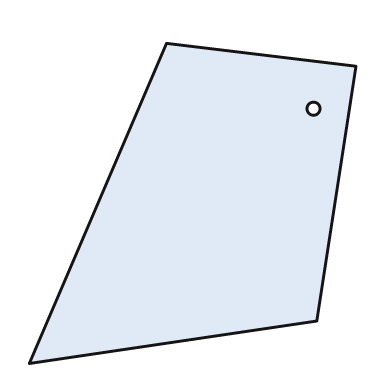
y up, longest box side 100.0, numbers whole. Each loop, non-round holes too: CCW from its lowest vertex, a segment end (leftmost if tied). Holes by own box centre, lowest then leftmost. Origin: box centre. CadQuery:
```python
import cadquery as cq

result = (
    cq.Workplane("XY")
    .moveTo(-50.0, -49.0)
    .lineTo(38.0, -36.0)
    .lineTo(50.0, 42.0)
    .lineTo(-8.0, 49.0)
    .close()
    .moveTo(37.0, 29.0)
    .circle(2.0)
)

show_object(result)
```